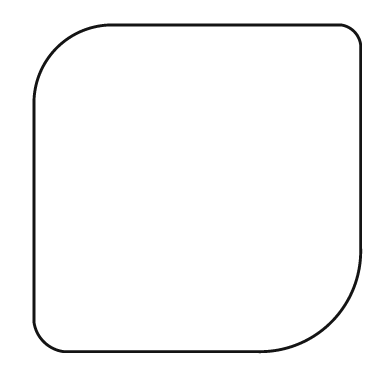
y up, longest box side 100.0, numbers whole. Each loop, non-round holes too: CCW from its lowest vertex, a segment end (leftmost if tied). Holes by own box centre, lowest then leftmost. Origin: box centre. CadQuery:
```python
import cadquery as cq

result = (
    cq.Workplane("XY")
    .moveTo(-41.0, -50.0)
    .lineTo(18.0, -50.0)
    .threePointArc((41.0, -41.0), (50.0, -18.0))
    .lineTo(50.0, 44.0)
    .threePointArc((48.0, 48.0), (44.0, 50.0))
    .lineTo(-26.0, 50.0)
    .threePointArc((-43.0, 43.0), (-50.0, 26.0))
    .lineTo(-50.0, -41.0)
    .threePointArc((-47.0, -47.0), (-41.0, -50.0))
    .close()
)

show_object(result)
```